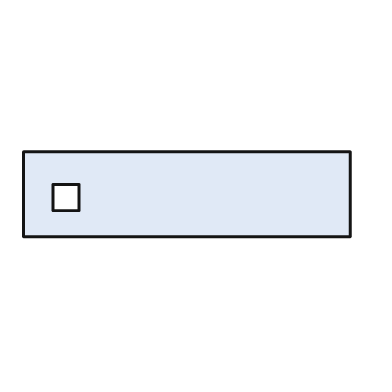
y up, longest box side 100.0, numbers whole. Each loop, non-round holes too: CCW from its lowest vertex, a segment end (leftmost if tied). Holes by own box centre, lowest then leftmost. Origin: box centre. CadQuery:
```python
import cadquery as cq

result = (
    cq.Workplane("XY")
    .moveTo(-50.0, -13.0)
    .lineTo(50.0, -13.0)
    .lineTo(50.0, 13.0)
    .lineTo(-50.0, 13.0)
    .close()
    .moveTo(-41.0, -5.0)
    .lineTo(-33.0, -5.0)
    .lineTo(-33.0, 3.0)
    .lineTo(-41.0, 3.0)
    .close()
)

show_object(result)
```